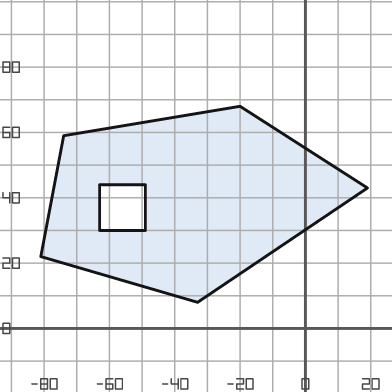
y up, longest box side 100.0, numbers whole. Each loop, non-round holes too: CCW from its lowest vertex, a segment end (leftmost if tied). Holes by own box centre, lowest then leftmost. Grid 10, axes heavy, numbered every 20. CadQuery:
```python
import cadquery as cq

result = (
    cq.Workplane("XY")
    .moveTo(-33.0, 8.0)
    .lineTo(19.0, 43.0)
    .lineTo(-20.0, 68.0)
    .lineTo(-74.0, 59.0)
    .lineTo(-81.0, 22.0)
    .close()
    .moveTo(-63.0, 30.0)
    .lineTo(-49.0, 30.0)
    .lineTo(-49.0, 44.0)
    .lineTo(-63.0, 44.0)
    .close()
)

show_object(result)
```